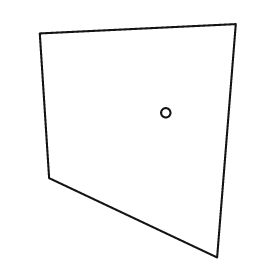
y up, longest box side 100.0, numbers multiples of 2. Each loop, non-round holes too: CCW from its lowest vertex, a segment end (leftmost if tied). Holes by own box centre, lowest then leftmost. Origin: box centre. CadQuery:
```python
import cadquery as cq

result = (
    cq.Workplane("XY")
    .moveTo(34.0, -50.0)
    .lineTo(42.0, 50.0)
    .lineTo(-42.0, 46.0)
    .lineTo(-38.0, -16.0)
    .close()
    .moveTo(12.0, 12.0)
    .circle(2.0)
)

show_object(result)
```